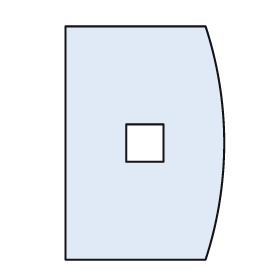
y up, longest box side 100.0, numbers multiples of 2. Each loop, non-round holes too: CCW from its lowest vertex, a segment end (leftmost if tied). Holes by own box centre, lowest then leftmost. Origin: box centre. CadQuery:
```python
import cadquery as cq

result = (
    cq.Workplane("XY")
    .moveTo(-34.0, -50.0)
    .lineTo(26.0, -50.0)
    .threePointArc((34.0, 0.0), (26.0, 50.0))
    .lineTo(-34.0, 50.0)
    .close()
    .moveTo(-8.0, -8.0)
    .lineTo(8.0, -8.0)
    .lineTo(8.0, 8.0)
    .lineTo(-8.0, 8.0)
    .close()
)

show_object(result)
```